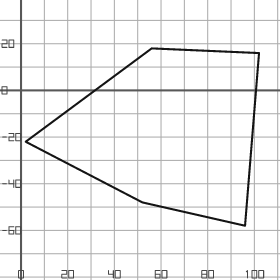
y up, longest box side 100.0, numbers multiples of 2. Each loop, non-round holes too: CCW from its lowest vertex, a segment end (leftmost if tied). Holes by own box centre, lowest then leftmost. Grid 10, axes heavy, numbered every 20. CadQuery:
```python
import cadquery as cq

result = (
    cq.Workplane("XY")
    .moveTo(96.0, -58.0)
    .lineTo(102.0, 16.0)
    .lineTo(56.0, 18.0)
    .lineTo(2.0, -22.0)
    .lineTo(52.0, -48.0)
    .close()
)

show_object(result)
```